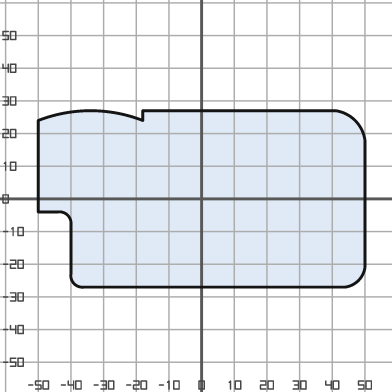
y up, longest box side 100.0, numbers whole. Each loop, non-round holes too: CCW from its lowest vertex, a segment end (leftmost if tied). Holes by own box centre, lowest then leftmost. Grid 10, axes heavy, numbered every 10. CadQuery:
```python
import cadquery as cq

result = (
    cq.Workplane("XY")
    .moveTo(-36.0, -27.0)
    .lineTo(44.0, -27.0)
    .threePointArc((48.0, -25.0), (50.0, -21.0))
    .lineTo(50.0, 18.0)
    .threePointArc((47.0, 24.0), (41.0, 27.0))
    .lineTo(-18.0, 27.0)
    .lineTo(-18.0, 24.0)
    .threePointArc((-34.0, 27.0), (-50.0, 24.0))
    .lineTo(-50.0, -4.0)
    .lineTo(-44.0, -4.0)
    .threePointArc((-41.0, -5.0), (-40.0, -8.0))
    .lineTo(-40.0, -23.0)
    .threePointArc((-39.0, -26.0), (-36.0, -27.0))
    .close()
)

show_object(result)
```